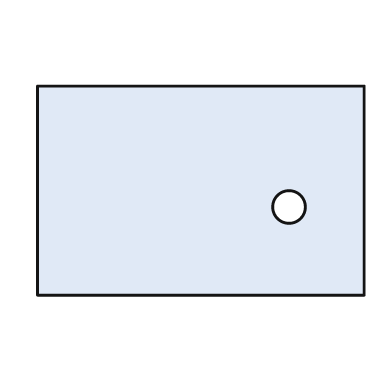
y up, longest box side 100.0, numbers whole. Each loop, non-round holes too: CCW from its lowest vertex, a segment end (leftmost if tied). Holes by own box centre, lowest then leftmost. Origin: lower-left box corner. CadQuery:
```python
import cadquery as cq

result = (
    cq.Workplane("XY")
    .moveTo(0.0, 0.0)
    .lineTo(100.0, 0.0)
    .lineTo(100.0, 64.0)
    .lineTo(0.0, 64.0)
    .close()
    .moveTo(77.0, 27.0)
    .circle(5.0)
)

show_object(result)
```